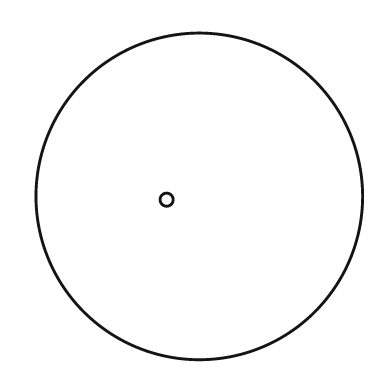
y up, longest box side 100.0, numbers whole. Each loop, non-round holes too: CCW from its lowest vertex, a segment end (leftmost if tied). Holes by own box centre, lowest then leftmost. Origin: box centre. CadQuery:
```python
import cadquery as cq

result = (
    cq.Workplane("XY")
    .moveTo(0.0, 0.0)
    .circle(50.0)
    .moveTo(-10.0, -1.0)
    .circle(2.0)
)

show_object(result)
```